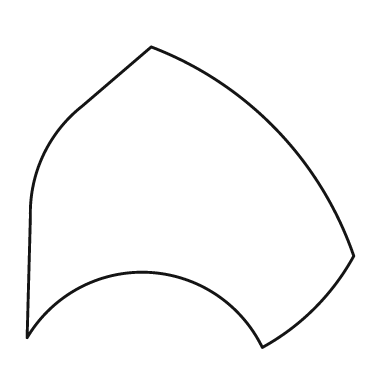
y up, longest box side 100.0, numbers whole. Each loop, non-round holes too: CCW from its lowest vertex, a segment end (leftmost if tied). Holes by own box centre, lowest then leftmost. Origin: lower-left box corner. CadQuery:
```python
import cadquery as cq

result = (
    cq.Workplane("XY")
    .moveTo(72.0, 0.0)
    .threePointArc((88.0, 12.0), (100.0, 28.0))
    .threePointArc((76.0, 67.0), (38.0, 92.0))
    .lineTo(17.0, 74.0)
    .threePointArc((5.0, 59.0), (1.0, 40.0))
    .lineTo(0.0, 3.0)
    .threePointArc((37.0, 23.0), (72.0, 0.0))
    .close()
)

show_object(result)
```